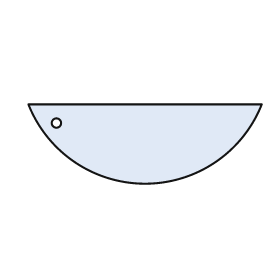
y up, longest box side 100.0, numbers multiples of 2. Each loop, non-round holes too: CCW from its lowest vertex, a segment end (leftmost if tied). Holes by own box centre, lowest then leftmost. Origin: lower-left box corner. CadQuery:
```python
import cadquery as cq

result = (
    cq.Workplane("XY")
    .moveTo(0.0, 34.0)
    .threePointArc((50.0, 0.0), (100.0, 34.0))
    .close()
    .moveTo(12.0, 26.0)
    .circle(2.0)
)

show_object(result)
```